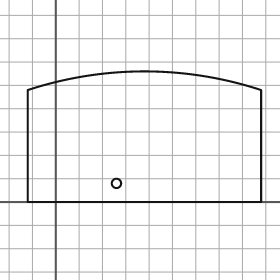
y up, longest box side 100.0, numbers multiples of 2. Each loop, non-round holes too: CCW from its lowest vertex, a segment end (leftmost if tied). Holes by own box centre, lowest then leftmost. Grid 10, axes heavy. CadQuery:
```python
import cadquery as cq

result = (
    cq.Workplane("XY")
    .moveTo(-12.0, 0.0)
    .lineTo(88.0, 0.0)
    .lineTo(88.0, 48.0)
    .threePointArc((38.0, 56.0), (-12.0, 48.0))
    .close()
    .moveTo(26.0, 8.0)
    .circle(2.0)
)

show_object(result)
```